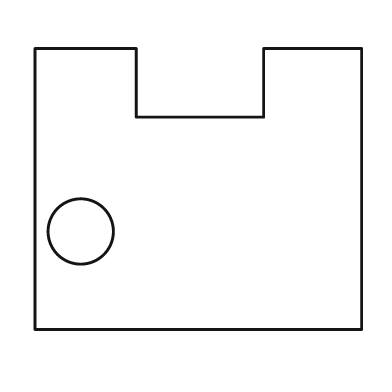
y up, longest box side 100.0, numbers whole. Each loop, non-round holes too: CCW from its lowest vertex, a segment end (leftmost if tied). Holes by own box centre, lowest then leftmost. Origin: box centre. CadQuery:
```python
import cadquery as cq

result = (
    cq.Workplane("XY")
    .moveTo(-50.0, -43.0)
    .lineTo(50.0, -43.0)
    .lineTo(50.0, 43.0)
    .lineTo(20.0, 43.0)
    .lineTo(20.0, 22.0)
    .lineTo(-19.0, 22.0)
    .lineTo(-19.0, 43.0)
    .lineTo(-50.0, 43.0)
    .close()
    .moveTo(-36.0, -13.0)
    .circle(10.0)
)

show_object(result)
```